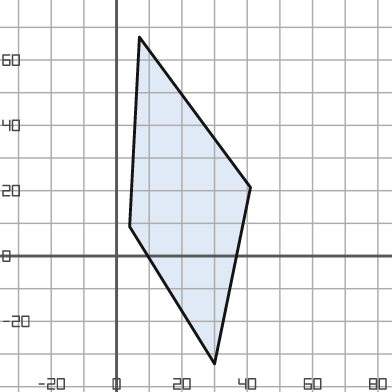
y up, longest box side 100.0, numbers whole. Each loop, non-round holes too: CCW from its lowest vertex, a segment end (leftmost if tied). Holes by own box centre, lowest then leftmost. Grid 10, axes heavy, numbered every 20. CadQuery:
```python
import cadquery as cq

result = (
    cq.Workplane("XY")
    .moveTo(30.0, -33.0)
    .lineTo(41.0, 21.0)
    .lineTo(7.0, 67.0)
    .lineTo(4.0, 9.0)
    .close()
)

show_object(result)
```